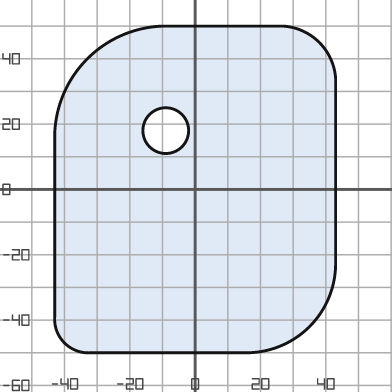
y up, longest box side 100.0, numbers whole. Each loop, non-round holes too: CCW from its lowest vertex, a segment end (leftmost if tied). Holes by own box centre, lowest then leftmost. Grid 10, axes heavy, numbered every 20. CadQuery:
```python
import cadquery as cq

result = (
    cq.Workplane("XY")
    .moveTo(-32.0, -50.0)
    .lineTo(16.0, -50.0)
    .threePointArc((35.0, -42.0), (43.0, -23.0))
    .lineTo(43.0, 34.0)
    .threePointArc((38.0, 45.0), (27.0, 50.0))
    .lineTo(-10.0, 50.0)
    .threePointArc((-33.0, 40.0), (-43.0, 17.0))
    .lineTo(-43.0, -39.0)
    .threePointArc((-40.0, -47.0), (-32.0, -50.0))
    .close()
    .moveTo(-9.0, 18.0)
    .circle(7.0)
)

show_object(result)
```